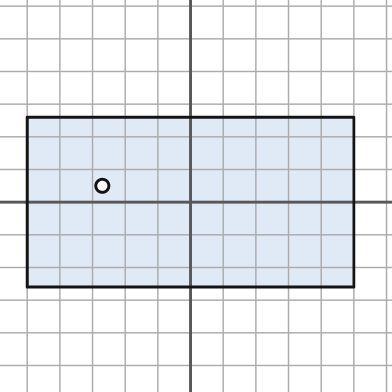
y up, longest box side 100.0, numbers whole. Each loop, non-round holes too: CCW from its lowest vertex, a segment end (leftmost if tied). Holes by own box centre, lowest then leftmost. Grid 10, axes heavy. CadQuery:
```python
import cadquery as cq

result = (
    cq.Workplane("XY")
    .moveTo(-50.0, -26.0)
    .lineTo(50.0, -26.0)
    .lineTo(50.0, 26.0)
    .lineTo(-50.0, 26.0)
    .close()
    .moveTo(-27.0, 5.0)
    .circle(2.0)
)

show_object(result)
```